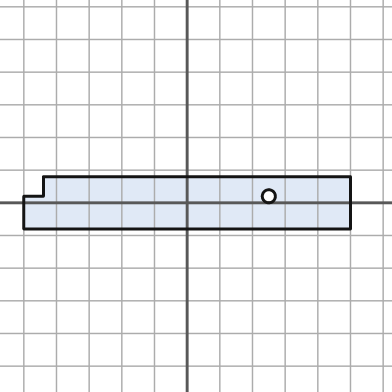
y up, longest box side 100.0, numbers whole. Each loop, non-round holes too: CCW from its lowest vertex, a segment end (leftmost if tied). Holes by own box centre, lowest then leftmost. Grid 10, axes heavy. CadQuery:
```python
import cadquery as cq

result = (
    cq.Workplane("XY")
    .moveTo(-50.0, -8.0)
    .lineTo(50.0, -8.0)
    .lineTo(50.0, 8.0)
    .lineTo(-44.0, 8.0)
    .lineTo(-44.0, 2.0)
    .lineTo(-50.0, 2.0)
    .close()
    .moveTo(25.0, 2.0)
    .circle(2.0)
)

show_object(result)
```